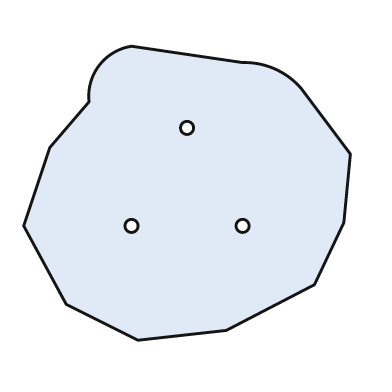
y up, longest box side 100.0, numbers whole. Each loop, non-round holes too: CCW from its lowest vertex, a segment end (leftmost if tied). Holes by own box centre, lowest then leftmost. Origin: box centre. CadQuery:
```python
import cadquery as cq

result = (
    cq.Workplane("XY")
    .moveTo(-15.0, -45.0)
    .lineTo(12.0, -42.0)
    .lineTo(39.0, -28.0)
    .lineTo(48.0, -9.0)
    .lineTo(50.0, 12.0)
    .lineTo(35.0, 32.0)
    .threePointArc((27.0, 38.0), (17.0, 40.0))
    .lineTo(-17.0, 45.0)
    .threePointArc((-27.0, 39.0), (-30.0, 28.0))
    .lineTo(-42.0, 14.0)
    .lineTo(-50.0, -10.0)
    .lineTo(-37.0, -34.0)
    .close()
    .moveTo(-17.0, -10.0)
    .circle(2.0)
    .moveTo(17.0, -10.0)
    .circle(2.0)
    .moveTo(0.0, 20.0)
    .circle(2.0)
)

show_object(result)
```